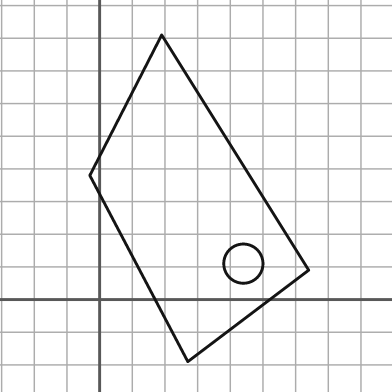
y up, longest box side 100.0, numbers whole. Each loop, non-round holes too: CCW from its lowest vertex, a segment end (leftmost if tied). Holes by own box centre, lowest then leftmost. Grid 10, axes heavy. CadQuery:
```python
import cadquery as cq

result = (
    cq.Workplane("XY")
    .moveTo(27.0, -19.0)
    .lineTo(64.0, 9.0)
    .lineTo(19.0, 81.0)
    .lineTo(-3.0, 38.0)
    .close()
    .moveTo(44.0, 11.0)
    .circle(6.0)
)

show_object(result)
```